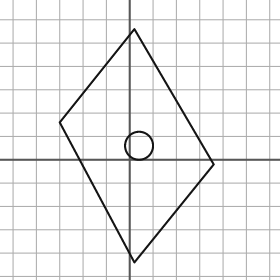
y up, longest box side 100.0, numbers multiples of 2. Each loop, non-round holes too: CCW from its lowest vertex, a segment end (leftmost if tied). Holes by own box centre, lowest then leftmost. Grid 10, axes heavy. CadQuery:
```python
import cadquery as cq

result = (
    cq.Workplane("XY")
    .moveTo(2.0, -44.0)
    .lineTo(36.0, -2.0)
    .lineTo(2.0, 56.0)
    .lineTo(-30.0, 16.0)
    .close()
    .moveTo(4.0, 6.0)
    .circle(6.0)
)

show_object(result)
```